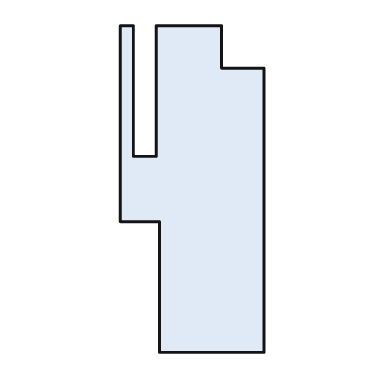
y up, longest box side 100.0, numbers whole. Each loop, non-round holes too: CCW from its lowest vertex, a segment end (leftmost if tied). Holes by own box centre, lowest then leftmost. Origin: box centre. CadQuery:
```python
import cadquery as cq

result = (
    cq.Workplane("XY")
    .moveTo(-10.0, -50.0)
    .lineTo(22.0, -50.0)
    .lineTo(22.0, 37.0)
    .lineTo(9.0, 37.0)
    .lineTo(9.0, 50.0)
    .lineTo(-11.0, 50.0)
    .lineTo(-11.0, 10.0)
    .lineTo(-18.0, 10.0)
    .lineTo(-18.0, 50.0)
    .lineTo(-22.0, 50.0)
    .lineTo(-22.0, -10.0)
    .lineTo(-10.0, -10.0)
    .close()
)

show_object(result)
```